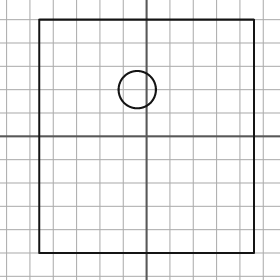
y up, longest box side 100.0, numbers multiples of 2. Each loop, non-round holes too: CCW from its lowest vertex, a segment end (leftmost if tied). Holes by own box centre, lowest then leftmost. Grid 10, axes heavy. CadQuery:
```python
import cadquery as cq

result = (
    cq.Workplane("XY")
    .moveTo(-46.0, -50.0)
    .lineTo(46.0, -50.0)
    .lineTo(46.0, 50.0)
    .lineTo(-46.0, 50.0)
    .close()
    .moveTo(-4.0, 20.0)
    .circle(8.0)
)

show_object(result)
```